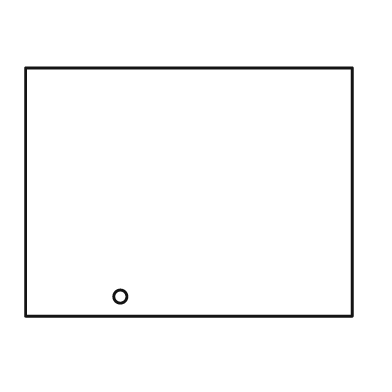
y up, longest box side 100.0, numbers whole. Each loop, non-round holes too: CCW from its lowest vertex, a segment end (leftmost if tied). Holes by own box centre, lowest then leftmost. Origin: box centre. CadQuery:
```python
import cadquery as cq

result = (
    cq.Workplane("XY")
    .moveTo(-50.0, -38.0)
    .lineTo(50.0, -38.0)
    .lineTo(50.0, 38.0)
    .lineTo(-50.0, 38.0)
    .close()
    .moveTo(-21.0, -32.0)
    .circle(2.0)
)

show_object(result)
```